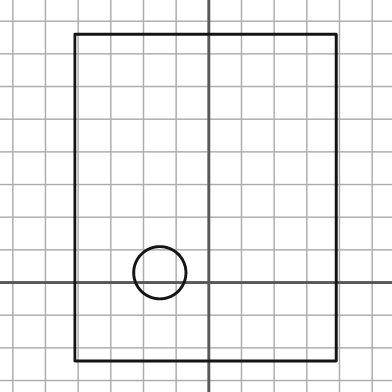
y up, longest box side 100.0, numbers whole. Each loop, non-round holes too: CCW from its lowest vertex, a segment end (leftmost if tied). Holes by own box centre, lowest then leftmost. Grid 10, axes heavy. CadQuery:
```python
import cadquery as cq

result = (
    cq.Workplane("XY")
    .moveTo(-41.0, -24.0)
    .lineTo(39.0, -24.0)
    .lineTo(39.0, 76.0)
    .lineTo(-41.0, 76.0)
    .close()
    .moveTo(-15.0, 3.0)
    .circle(8.0)
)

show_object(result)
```